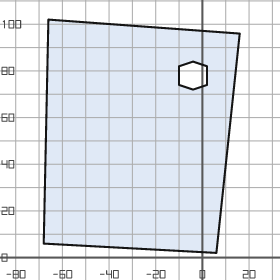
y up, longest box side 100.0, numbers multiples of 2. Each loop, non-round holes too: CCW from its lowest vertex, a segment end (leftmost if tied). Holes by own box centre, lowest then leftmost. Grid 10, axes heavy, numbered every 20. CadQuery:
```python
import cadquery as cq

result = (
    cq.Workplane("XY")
    .moveTo(6.0, 2.0)
    .lineTo(16.0, 96.0)
    .lineTo(-66.0, 102.0)
    .lineTo(-68.0, 6.0)
    .close()
    .moveTo(-4.0, 72.0)
    .lineTo(2.0, 74.0)
    .lineTo(2.0, 82.0)
    .lineTo(-4.0, 84.0)
    .lineTo(-10.0, 82.0)
    .lineTo(-10.0, 74.0)
    .close()
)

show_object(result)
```